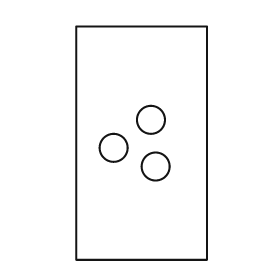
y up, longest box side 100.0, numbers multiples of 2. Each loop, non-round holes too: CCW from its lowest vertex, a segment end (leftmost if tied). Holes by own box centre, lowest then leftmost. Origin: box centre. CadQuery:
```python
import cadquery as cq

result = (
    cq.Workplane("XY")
    .moveTo(-28.0, -50.0)
    .lineTo(28.0, -50.0)
    .lineTo(28.0, 50.0)
    .lineTo(-28.0, 50.0)
    .close()
    .moveTo(6.0, -10.0)
    .circle(6.0)
    .moveTo(-12.0, -2.0)
    .circle(6.0)
    .moveTo(4.0, 10.0)
    .circle(6.0)
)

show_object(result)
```